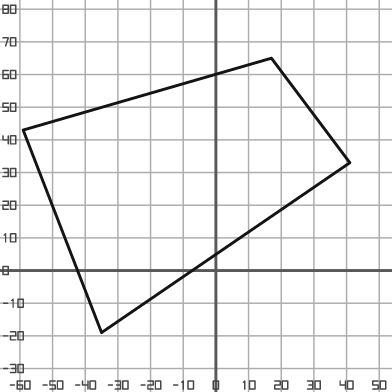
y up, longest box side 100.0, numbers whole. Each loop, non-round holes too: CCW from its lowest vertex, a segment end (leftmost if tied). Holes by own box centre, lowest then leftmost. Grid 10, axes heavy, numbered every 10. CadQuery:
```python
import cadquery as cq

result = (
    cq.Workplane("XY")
    .moveTo(-35.0, -19.0)
    .lineTo(41.0, 33.0)
    .lineTo(17.0, 65.0)
    .lineTo(-59.0, 43.0)
    .close()
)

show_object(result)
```